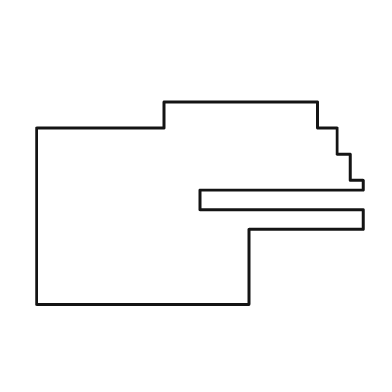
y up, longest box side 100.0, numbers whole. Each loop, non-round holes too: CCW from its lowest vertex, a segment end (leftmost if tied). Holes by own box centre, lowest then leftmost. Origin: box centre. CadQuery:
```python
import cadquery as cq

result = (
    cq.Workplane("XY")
    .moveTo(-50.0, -31.0)
    .lineTo(15.0, -31.0)
    .lineTo(15.0, -8.0)
    .lineTo(50.0, -8.0)
    .lineTo(50.0, -2.0)
    .lineTo(0.0, -2.0)
    .lineTo(0.0, 4.0)
    .lineTo(50.0, 4.0)
    .lineTo(50.0, 7.0)
    .lineTo(46.0, 7.0)
    .lineTo(46.0, 15.0)
    .lineTo(42.0, 15.0)
    .lineTo(42.0, 23.0)
    .lineTo(36.0, 23.0)
    .lineTo(36.0, 31.0)
    .lineTo(-11.0, 31.0)
    .lineTo(-11.0, 23.0)
    .lineTo(-50.0, 23.0)
    .close()
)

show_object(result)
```